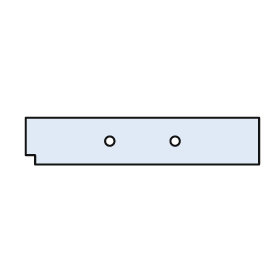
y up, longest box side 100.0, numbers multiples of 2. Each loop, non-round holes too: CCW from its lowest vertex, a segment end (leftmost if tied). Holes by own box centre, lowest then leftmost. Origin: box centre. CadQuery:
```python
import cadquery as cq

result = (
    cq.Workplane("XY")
    .moveTo(-46.0, -10.0)
    .lineTo(50.0, -10.0)
    .lineTo(50.0, 10.0)
    .lineTo(-50.0, 10.0)
    .lineTo(-50.0, -6.0)
    .lineTo(-46.0, -6.0)
    .close()
    .moveTo(-14.0, 0.0)
    .circle(2.0)
    .moveTo(14.0, 0.0)
    .circle(2.0)
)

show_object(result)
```